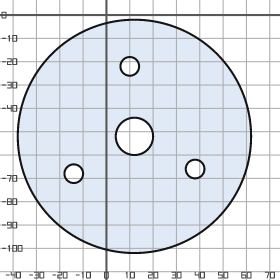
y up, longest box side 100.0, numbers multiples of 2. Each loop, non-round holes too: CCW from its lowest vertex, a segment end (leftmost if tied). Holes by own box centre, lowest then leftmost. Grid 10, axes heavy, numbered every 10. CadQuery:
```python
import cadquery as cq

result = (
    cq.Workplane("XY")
    .moveTo(12.0, -52.0)
    .circle(50.0)
    .moveTo(-14.0, -68.0)
    .circle(4.0)
    .moveTo(38.0, -66.0)
    .circle(4.0)
    .moveTo(12.0, -52.0)
    .circle(8.0)
    .moveTo(10.0, -22.0)
    .circle(4.0)
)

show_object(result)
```